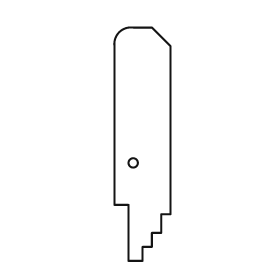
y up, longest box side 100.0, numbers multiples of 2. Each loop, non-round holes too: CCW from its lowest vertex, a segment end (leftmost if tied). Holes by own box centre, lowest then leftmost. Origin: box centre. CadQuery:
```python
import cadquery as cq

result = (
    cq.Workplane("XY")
    .moveTo(-6.0, -50.0)
    .lineTo(0.0, -50.0)
    .lineTo(0.0, -44.0)
    .lineTo(4.0, -44.0)
    .lineTo(4.0, -38.0)
    .lineTo(8.0, -38.0)
    .lineTo(8.0, -30.0)
    .lineTo(12.0, -30.0)
    .lineTo(12.0, 42.0)
    .lineTo(4.0, 50.0)
    .lineTo(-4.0, 50.0)
    .threePointArc((-10.0, 48.0), (-12.0, 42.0))
    .lineTo(-12.0, -26.0)
    .lineTo(-6.0, -26.0)
    .close()
    .moveTo(-4.0, -8.0)
    .circle(2.0)
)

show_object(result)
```